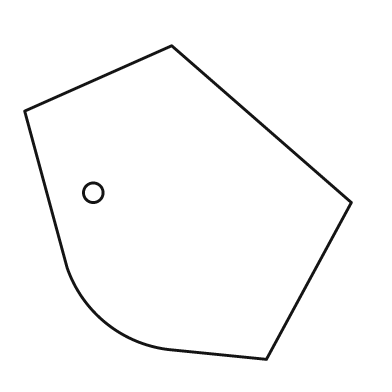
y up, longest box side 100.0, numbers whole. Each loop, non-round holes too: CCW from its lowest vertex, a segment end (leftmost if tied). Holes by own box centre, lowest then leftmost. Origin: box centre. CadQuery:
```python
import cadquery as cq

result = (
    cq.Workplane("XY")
    .moveTo(24.0, -48.0)
    .lineTo(50.0, 0.0)
    .lineTo(-5.0, 48.0)
    .lineTo(-50.0, 28.0)
    .lineTo(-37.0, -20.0)
    .threePointArc((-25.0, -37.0), (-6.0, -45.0))
    .close()
    .moveTo(-29.0, 3.0)
    .circle(3.0)
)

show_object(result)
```